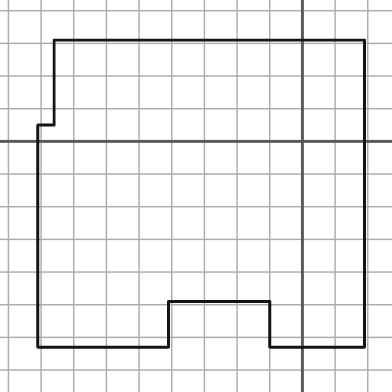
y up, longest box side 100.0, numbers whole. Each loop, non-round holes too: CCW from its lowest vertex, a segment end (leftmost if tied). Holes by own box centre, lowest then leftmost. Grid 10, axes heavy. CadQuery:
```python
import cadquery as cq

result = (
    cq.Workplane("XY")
    .moveTo(-81.0, -63.0)
    .lineTo(-41.0, -63.0)
    .lineTo(-41.0, -49.0)
    .lineTo(-10.0, -49.0)
    .lineTo(-10.0, -63.0)
    .lineTo(19.0, -63.0)
    .lineTo(19.0, 31.0)
    .lineTo(-76.0, 31.0)
    .lineTo(-76.0, 5.0)
    .lineTo(-81.0, 5.0)
    .close()
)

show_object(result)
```